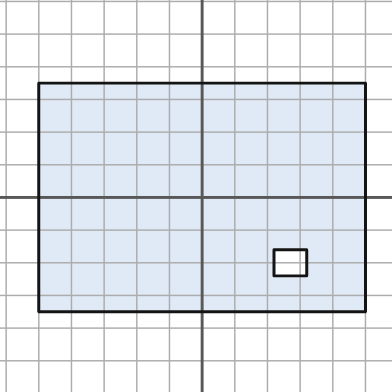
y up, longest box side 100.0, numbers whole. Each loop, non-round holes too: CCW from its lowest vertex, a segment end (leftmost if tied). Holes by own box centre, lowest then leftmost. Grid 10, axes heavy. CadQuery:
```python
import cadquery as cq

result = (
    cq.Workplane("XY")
    .moveTo(-50.0, -35.0)
    .lineTo(50.0, -35.0)
    .lineTo(50.0, 35.0)
    .lineTo(-50.0, 35.0)
    .close()
    .moveTo(22.0, -24.0)
    .lineTo(32.0, -24.0)
    .lineTo(32.0, -16.0)
    .lineTo(22.0, -16.0)
    .close()
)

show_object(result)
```